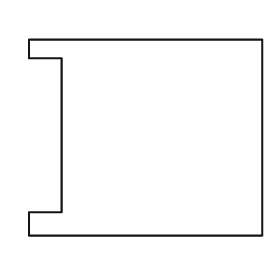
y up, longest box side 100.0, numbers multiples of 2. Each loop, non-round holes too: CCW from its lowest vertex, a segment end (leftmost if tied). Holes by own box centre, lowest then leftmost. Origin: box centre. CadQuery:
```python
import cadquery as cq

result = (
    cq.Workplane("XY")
    .moveTo(-50.0, -42.0)
    .lineTo(50.0, -42.0)
    .lineTo(50.0, 42.0)
    .lineTo(-50.0, 42.0)
    .lineTo(-50.0, 34.0)
    .lineTo(-36.0, 34.0)
    .lineTo(-36.0, -32.0)
    .lineTo(-50.0, -32.0)
    .close()
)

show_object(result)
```